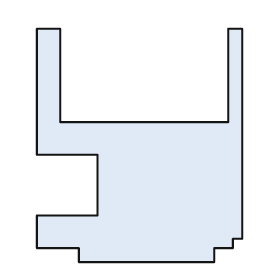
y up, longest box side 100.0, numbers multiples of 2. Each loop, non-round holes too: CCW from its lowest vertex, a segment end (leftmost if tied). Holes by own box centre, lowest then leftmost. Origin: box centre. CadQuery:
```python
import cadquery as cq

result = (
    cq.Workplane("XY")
    .moveTo(-26.0, -50.0)
    .lineTo(32.0, -50.0)
    .lineTo(32.0, -44.0)
    .lineTo(40.0, -44.0)
    .lineTo(40.0, -40.0)
    .lineTo(44.0, -40.0)
    .lineTo(44.0, 50.0)
    .lineTo(38.0, 50.0)
    .lineTo(38.0, 10.0)
    .lineTo(-34.0, 10.0)
    .lineTo(-34.0, 50.0)
    .lineTo(-44.0, 50.0)
    .lineTo(-44.0, -4.0)
    .lineTo(-18.0, -4.0)
    .lineTo(-18.0, -30.0)
    .lineTo(-44.0, -30.0)
    .lineTo(-44.0, -44.0)
    .lineTo(-26.0, -44.0)
    .close()
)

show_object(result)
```